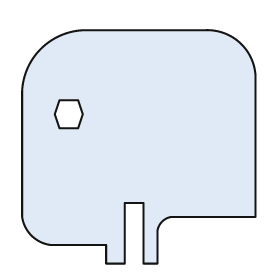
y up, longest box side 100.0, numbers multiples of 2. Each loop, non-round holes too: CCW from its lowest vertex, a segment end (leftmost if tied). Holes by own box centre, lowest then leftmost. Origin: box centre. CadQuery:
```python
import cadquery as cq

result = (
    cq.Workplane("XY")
    .moveTo(-14.0, -50.0)
    .lineTo(-6.0, -50.0)
    .lineTo(-6.0, -24.0)
    .lineTo(2.0, -24.0)
    .lineTo(2.0, -50.0)
    .lineTo(8.0, -50.0)
    .lineTo(8.0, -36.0)
    .threePointArc((10.0, -32.0), (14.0, -30.0))
    .lineTo(50.0, -30.0)
    .lineTo(50.0, 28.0)
    .threePointArc((44.0, 44.0), (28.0, 50.0))
    .lineTo(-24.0, 50.0)
    .threePointArc((-42.0, 42.0), (-50.0, 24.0))
    .lineTo(-50.0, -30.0)
    .threePointArc((-46.0, -38.0), (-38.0, -42.0))
    .lineTo(-14.0, -42.0)
    .close()
    .moveTo(-34.0, 8.0)
    .lineTo(-26.0, 8.0)
    .lineTo(-24.0, 14.0)
    .lineTo(-26.0, 20.0)
    .lineTo(-34.0, 20.0)
    .lineTo(-36.0, 14.0)
    .close()
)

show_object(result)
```